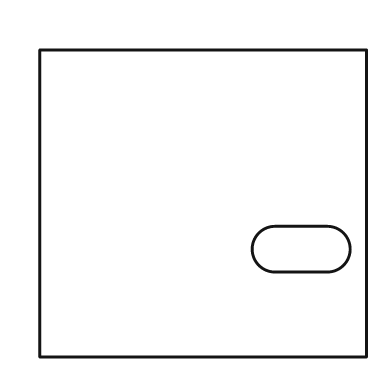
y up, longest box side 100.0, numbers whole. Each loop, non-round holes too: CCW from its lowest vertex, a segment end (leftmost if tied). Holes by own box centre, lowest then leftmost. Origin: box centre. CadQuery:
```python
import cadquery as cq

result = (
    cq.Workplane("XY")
    .moveTo(-50.0, -47.0)
    .lineTo(50.0, -47.0)
    .lineTo(50.0, 47.0)
    .lineTo(-50.0, 47.0)
    .close()
    .moveTo(22.0, -21.0)
    .lineTo(38.0, -21.0)
    .threePointArc((45.0, -14.0), (38.0, -7.0))
    .lineTo(22.0, -7.0)
    .threePointArc((15.0, -14.0), (22.0, -21.0))
    .close()
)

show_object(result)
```